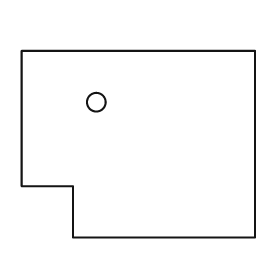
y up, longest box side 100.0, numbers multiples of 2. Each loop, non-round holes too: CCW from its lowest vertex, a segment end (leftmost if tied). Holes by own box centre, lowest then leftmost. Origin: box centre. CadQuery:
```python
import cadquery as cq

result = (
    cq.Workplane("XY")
    .moveTo(-28.0, -40.0)
    .lineTo(50.0, -40.0)
    .lineTo(50.0, 40.0)
    .lineTo(-50.0, 40.0)
    .lineTo(-50.0, -18.0)
    .lineTo(-28.0, -18.0)
    .close()
    .moveTo(-18.0, 18.0)
    .circle(4.0)
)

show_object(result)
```